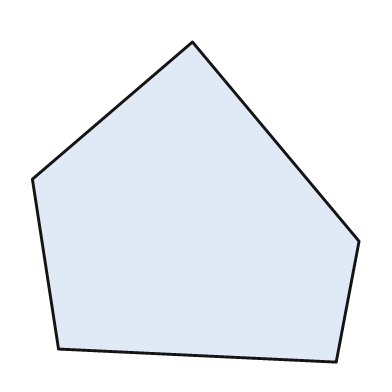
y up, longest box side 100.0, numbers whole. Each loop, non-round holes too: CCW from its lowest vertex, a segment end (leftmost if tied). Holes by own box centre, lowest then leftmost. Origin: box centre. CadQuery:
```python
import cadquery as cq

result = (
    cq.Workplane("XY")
    .moveTo(43.0, -49.0)
    .lineTo(50.0, -12.0)
    .lineTo(-1.0, 49.0)
    .lineTo(-50.0, 7.0)
    .lineTo(-42.0, -45.0)
    .close()
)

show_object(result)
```